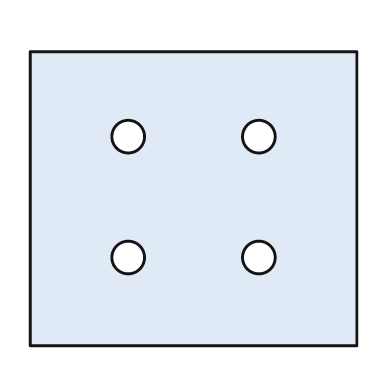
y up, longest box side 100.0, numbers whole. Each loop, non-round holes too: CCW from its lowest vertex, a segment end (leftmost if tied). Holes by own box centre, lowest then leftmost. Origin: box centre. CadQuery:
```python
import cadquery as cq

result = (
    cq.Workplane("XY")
    .moveTo(-50.0, -45.0)
    .lineTo(50.0, -45.0)
    .lineTo(50.0, 45.0)
    .lineTo(-50.0, 45.0)
    .close()
    .moveTo(-20.0, -18.0)
    .circle(5.0)
    .moveTo(20.0, -18.0)
    .circle(5.0)
    .moveTo(-20.0, 19.0)
    .circle(5.0)
    .moveTo(20.0, 19.0)
    .circle(5.0)
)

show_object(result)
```